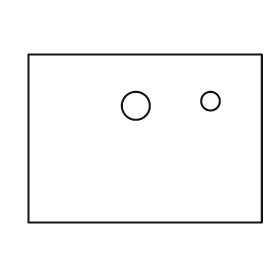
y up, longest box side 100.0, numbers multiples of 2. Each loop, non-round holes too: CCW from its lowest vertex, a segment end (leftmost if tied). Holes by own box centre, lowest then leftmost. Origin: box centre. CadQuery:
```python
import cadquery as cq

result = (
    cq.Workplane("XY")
    .moveTo(-50.0, -36.0)
    .lineTo(50.0, -36.0)
    .lineTo(50.0, 36.0)
    .lineTo(-50.0, 36.0)
    .close()
    .moveTo(-4.0, 14.0)
    .circle(6.0)
    .moveTo(28.0, 16.0)
    .circle(4.0)
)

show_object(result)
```